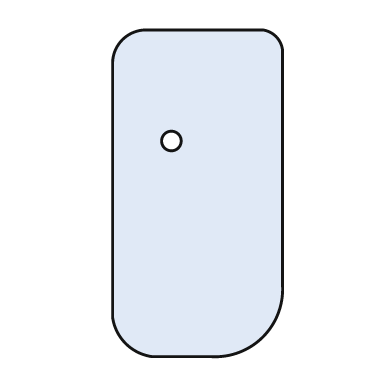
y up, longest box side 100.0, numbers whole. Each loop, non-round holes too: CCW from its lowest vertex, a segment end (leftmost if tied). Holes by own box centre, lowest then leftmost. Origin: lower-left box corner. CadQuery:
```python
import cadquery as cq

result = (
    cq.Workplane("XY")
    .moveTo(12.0, 0.0)
    .lineTo(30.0, 0.0)
    .threePointArc((46.0, 6.0), (52.0, 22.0))
    .lineTo(52.0, 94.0)
    .threePointArc((50.0, 98.0), (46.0, 100.0))
    .lineTo(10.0, 100.0)
    .threePointArc((3.0, 97.0), (0.0, 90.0))
    .lineTo(0.0, 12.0)
    .threePointArc((4.0, 4.0), (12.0, 0.0))
    .close()
    .moveTo(18.0, 66.0)
    .circle(3.0)
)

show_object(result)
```